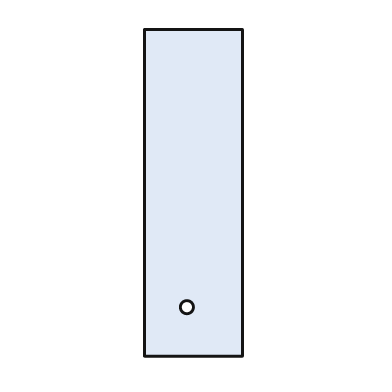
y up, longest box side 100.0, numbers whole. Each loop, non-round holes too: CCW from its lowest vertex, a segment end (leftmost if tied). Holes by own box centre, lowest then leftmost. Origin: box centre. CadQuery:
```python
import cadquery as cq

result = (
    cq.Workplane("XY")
    .moveTo(-15.0, -50.0)
    .lineTo(15.0, -50.0)
    .lineTo(15.0, 50.0)
    .lineTo(-15.0, 50.0)
    .close()
    .moveTo(-2.0, -35.0)
    .circle(2.0)
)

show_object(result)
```